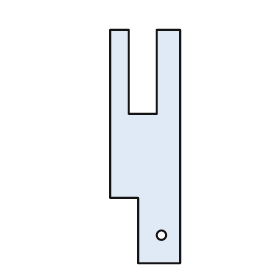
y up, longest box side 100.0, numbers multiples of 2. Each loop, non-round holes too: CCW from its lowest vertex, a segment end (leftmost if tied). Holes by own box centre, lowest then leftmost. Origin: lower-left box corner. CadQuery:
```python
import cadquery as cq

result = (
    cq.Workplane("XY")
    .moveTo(12.0, 0.0)
    .lineTo(30.0, 0.0)
    .lineTo(30.0, 100.0)
    .lineTo(20.0, 100.0)
    .lineTo(20.0, 64.0)
    .lineTo(8.0, 64.0)
    .lineTo(8.0, 100.0)
    .lineTo(0.0, 100.0)
    .lineTo(0.0, 28.0)
    .lineTo(12.0, 28.0)
    .close()
    .moveTo(22.0, 12.0)
    .circle(2.0)
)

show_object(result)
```